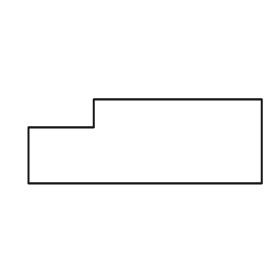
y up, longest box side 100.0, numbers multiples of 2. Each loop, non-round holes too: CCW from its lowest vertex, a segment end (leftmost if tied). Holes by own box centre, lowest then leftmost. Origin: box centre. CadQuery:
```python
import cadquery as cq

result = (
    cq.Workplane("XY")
    .moveTo(-50.0, -18.0)
    .lineTo(50.0, -18.0)
    .lineTo(50.0, 18.0)
    .lineTo(-22.0, 18.0)
    .lineTo(-22.0, 6.0)
    .lineTo(-50.0, 6.0)
    .close()
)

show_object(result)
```